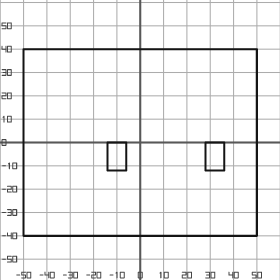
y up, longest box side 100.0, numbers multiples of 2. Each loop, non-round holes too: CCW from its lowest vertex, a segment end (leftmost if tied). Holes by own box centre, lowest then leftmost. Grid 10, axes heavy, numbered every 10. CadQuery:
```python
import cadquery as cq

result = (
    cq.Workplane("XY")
    .moveTo(-50.0, -40.0)
    .lineTo(50.0, -40.0)
    .lineTo(50.0, 40.0)
    .lineTo(-50.0, 40.0)
    .close()
    .moveTo(-14.0, -12.0)
    .lineTo(-6.0, -12.0)
    .lineTo(-6.0, 0.0)
    .lineTo(-14.0, 0.0)
    .close()
    .moveTo(28.0, -12.0)
    .lineTo(36.0, -12.0)
    .lineTo(36.0, 0.0)
    .lineTo(28.0, 0.0)
    .close()
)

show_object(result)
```